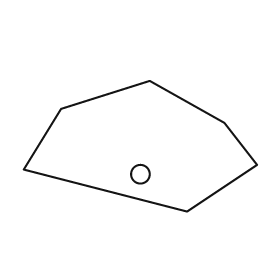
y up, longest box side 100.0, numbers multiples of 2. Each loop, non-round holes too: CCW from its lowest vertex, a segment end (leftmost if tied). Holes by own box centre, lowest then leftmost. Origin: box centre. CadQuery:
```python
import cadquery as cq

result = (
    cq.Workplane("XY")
    .moveTo(20.0, -28.0)
    .lineTo(50.0, -8.0)
    .lineTo(36.0, 10.0)
    .lineTo(4.0, 28.0)
    .lineTo(-34.0, 16.0)
    .lineTo(-50.0, -10.0)
    .close()
    .moveTo(0.0, -12.0)
    .circle(4.0)
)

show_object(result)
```